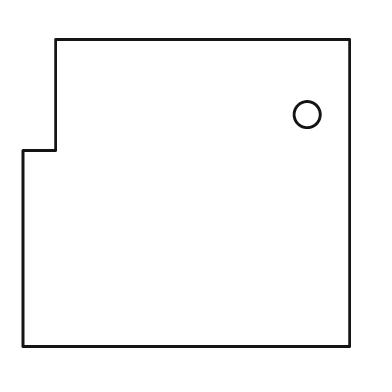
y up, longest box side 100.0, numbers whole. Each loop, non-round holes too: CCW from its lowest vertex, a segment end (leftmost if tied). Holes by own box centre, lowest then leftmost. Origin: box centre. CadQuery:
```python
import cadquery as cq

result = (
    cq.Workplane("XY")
    .moveTo(-50.0, -47.0)
    .lineTo(50.0, -47.0)
    .lineTo(50.0, 47.0)
    .lineTo(-40.0, 47.0)
    .lineTo(-40.0, 13.0)
    .lineTo(-50.0, 13.0)
    .close()
    .moveTo(37.0, 24.0)
    .circle(4.0)
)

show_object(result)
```